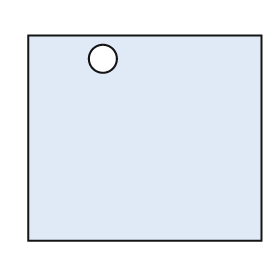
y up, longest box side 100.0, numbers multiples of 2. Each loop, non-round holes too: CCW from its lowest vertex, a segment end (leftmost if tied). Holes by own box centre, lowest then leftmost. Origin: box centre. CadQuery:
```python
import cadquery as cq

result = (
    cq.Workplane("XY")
    .moveTo(-50.0, -44.0)
    .lineTo(50.0, -44.0)
    .lineTo(50.0, 44.0)
    .lineTo(-50.0, 44.0)
    .close()
    .moveTo(-18.0, 34.0)
    .circle(6.0)
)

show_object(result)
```